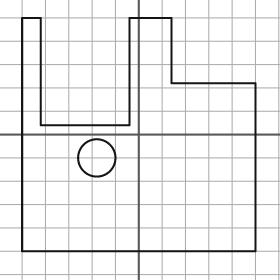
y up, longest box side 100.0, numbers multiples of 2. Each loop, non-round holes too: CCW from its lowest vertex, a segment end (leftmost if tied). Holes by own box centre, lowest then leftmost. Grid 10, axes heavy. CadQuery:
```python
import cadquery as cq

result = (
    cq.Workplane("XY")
    .moveTo(-50.0, -50.0)
    .lineTo(50.0, -50.0)
    .lineTo(50.0, 22.0)
    .lineTo(14.0, 22.0)
    .lineTo(14.0, 50.0)
    .lineTo(-4.0, 50.0)
    .lineTo(-4.0, 4.0)
    .lineTo(-42.0, 4.0)
    .lineTo(-42.0, 50.0)
    .lineTo(-50.0, 50.0)
    .close()
    .moveTo(-18.0, -10.0)
    .circle(8.0)
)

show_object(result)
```